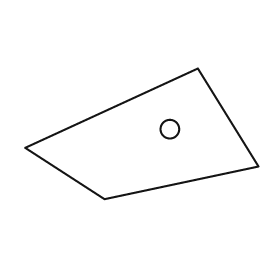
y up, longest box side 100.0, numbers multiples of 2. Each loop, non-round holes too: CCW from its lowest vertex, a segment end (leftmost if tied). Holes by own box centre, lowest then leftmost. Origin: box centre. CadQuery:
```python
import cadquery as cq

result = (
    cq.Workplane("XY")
    .moveTo(-16.0, -28.0)
    .lineTo(50.0, -14.0)
    .lineTo(24.0, 28.0)
    .lineTo(-50.0, -6.0)
    .close()
    .moveTo(12.0, 2.0)
    .circle(4.0)
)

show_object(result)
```